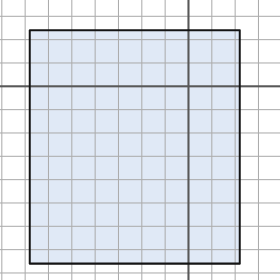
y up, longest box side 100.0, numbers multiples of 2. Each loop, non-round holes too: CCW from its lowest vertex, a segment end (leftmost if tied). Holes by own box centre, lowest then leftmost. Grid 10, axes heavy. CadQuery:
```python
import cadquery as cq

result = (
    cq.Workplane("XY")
    .moveTo(-68.0, -76.0)
    .lineTo(22.0, -76.0)
    .lineTo(22.0, 24.0)
    .lineTo(-68.0, 24.0)
    .close()
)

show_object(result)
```